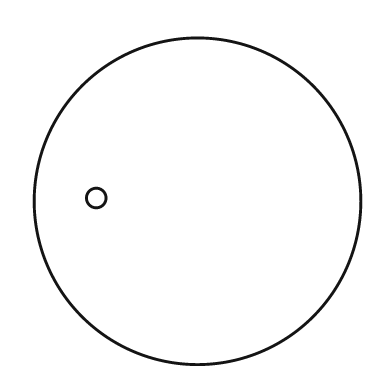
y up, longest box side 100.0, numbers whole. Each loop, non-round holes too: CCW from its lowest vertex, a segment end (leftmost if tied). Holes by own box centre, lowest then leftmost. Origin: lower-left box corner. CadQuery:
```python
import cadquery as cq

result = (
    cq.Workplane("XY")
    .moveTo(50.0, 50.0)
    .circle(50.0)
    .moveTo(19.0, 51.0)
    .circle(3.0)
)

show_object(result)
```